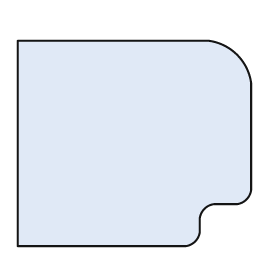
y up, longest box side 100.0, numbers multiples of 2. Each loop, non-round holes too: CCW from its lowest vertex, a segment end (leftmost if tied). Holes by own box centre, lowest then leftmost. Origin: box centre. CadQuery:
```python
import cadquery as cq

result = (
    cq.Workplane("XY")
    .moveTo(-50.0, -44.0)
    .lineTo(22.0, -44.0)
    .threePointArc((26.0, -42.0), (28.0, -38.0))
    .lineTo(28.0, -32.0)
    .threePointArc((30.0, -28.0), (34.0, -26.0))
    .lineTo(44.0, -26.0)
    .threePointArc((48.0, -24.0), (50.0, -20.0))
    .lineTo(50.0, 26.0)
    .threePointArc((44.0, 38.0), (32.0, 44.0))
    .lineTo(-50.0, 44.0)
    .close()
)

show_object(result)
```